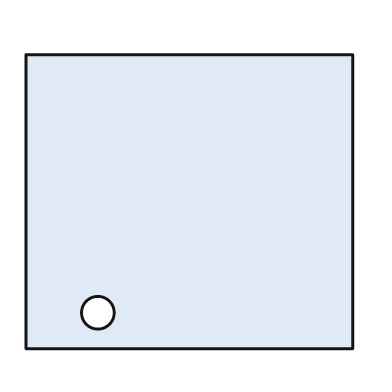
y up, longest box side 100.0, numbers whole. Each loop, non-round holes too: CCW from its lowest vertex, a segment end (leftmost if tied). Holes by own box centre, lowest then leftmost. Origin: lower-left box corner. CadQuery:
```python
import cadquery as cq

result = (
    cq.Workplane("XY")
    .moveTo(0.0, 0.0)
    .lineTo(100.0, 0.0)
    .lineTo(100.0, 90.0)
    .lineTo(0.0, 90.0)
    .close()
    .moveTo(22.0, 11.0)
    .circle(5.0)
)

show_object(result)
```